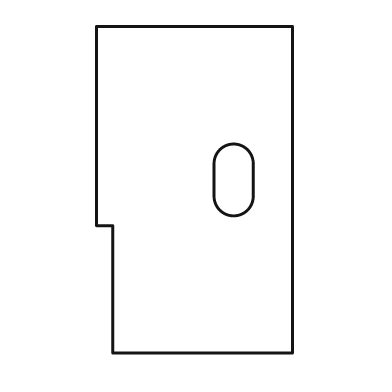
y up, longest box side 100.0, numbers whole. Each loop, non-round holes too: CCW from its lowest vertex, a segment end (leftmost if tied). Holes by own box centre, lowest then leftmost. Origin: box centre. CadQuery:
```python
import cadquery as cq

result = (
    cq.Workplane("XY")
    .moveTo(-25.0, -50.0)
    .lineTo(30.0, -50.0)
    .lineTo(30.0, 50.0)
    .lineTo(-30.0, 50.0)
    .lineTo(-30.0, -11.0)
    .lineTo(-25.0, -11.0)
    .close()
    .moveTo(6.0, -2.0)
    .threePointArc((12.0, -8.0), (18.0, -2.0))
    .lineTo(18.0, 8.0)
    .threePointArc((12.0, 14.0), (6.0, 8.0))
    .close()
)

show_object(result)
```